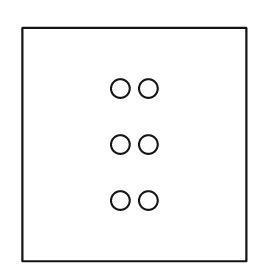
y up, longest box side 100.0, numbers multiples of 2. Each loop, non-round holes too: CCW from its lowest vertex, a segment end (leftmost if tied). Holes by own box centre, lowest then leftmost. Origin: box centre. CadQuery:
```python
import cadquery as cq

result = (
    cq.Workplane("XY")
    .moveTo(-48.0, -50.0)
    .lineTo(48.0, -50.0)
    .lineTo(48.0, 50.0)
    .lineTo(-48.0, 50.0)
    .close()
    .moveTo(-6.0, -24.0)
    .circle(4.0)
    .moveTo(6.0, -24.0)
    .circle(4.0)
    .moveTo(-6.0, 0.0)
    .circle(4.0)
    .moveTo(6.0, 0.0)
    .circle(4.0)
    .moveTo(-6.0, 24.0)
    .circle(4.0)
    .moveTo(6.0, 24.0)
    .circle(4.0)
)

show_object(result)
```